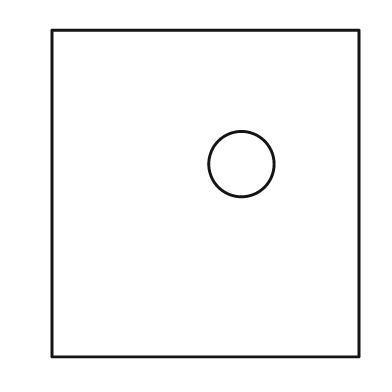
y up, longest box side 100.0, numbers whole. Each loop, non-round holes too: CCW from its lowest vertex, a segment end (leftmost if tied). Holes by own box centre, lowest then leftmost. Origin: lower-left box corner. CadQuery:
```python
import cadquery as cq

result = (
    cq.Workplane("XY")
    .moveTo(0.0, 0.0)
    .lineTo(94.0, 0.0)
    .lineTo(94.0, 100.0)
    .lineTo(0.0, 100.0)
    .close()
    .moveTo(58.0, 59.0)
    .circle(10.0)
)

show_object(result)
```